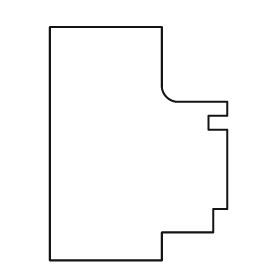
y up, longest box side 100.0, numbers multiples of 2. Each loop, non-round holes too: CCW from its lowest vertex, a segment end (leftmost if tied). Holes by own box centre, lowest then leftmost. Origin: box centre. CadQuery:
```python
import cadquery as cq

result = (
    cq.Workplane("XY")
    .moveTo(-38.0, -50.0)
    .lineTo(10.0, -50.0)
    .lineTo(10.0, -38.0)
    .lineTo(32.0, -38.0)
    .lineTo(32.0, -28.0)
    .lineTo(38.0, -28.0)
    .lineTo(38.0, 6.0)
    .lineTo(30.0, 6.0)
    .lineTo(30.0, 12.0)
    .lineTo(38.0, 12.0)
    .lineTo(38.0, 18.0)
    .lineTo(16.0, 18.0)
    .threePointArc((12.0, 20.0), (10.0, 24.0))
    .lineTo(10.0, 50.0)
    .lineTo(-38.0, 50.0)
    .close()
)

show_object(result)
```